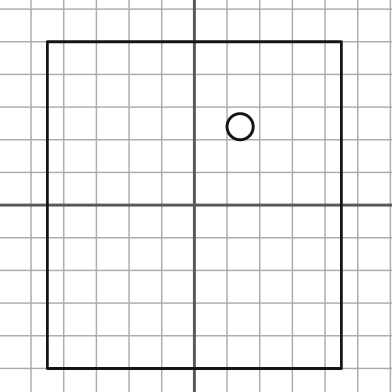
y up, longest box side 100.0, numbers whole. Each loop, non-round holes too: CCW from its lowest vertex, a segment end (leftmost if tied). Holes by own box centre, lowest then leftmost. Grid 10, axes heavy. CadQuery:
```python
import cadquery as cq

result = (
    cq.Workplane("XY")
    .moveTo(-45.0, -50.0)
    .lineTo(45.0, -50.0)
    .lineTo(45.0, 50.0)
    .lineTo(-45.0, 50.0)
    .close()
    .moveTo(14.0, 24.0)
    .circle(4.0)
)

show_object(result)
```